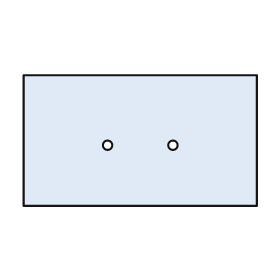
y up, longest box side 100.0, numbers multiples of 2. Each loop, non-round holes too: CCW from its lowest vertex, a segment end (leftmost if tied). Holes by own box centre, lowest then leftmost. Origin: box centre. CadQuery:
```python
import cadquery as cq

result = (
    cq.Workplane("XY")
    .moveTo(-50.0, -28.0)
    .lineTo(50.0, -28.0)
    .lineTo(50.0, 28.0)
    .lineTo(-50.0, 28.0)
    .close()
    .moveTo(-14.0, -2.0)
    .circle(2.0)
    .moveTo(14.0, -2.0)
    .circle(2.0)
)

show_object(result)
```